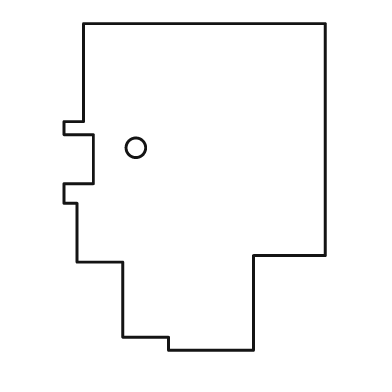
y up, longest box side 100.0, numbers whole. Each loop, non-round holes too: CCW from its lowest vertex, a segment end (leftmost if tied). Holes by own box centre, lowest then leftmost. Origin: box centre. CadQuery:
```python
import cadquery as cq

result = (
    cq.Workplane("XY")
    .moveTo(-8.0, -50.0)
    .lineTo(18.0, -50.0)
    .lineTo(18.0, -21.0)
    .lineTo(40.0, -21.0)
    .lineTo(40.0, 50.0)
    .lineTo(-34.0, 50.0)
    .lineTo(-34.0, 20.0)
    .lineTo(-40.0, 20.0)
    .lineTo(-40.0, 16.0)
    .lineTo(-31.0, 16.0)
    .lineTo(-31.0, 1.0)
    .lineTo(-40.0, 1.0)
    .lineTo(-40.0, -5.0)
    .lineTo(-36.0, -5.0)
    .lineTo(-36.0, -23.0)
    .lineTo(-22.0, -23.0)
    .lineTo(-22.0, -46.0)
    .lineTo(-8.0, -46.0)
    .close()
    .moveTo(-18.0, 12.0)
    .circle(3.0)
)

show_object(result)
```